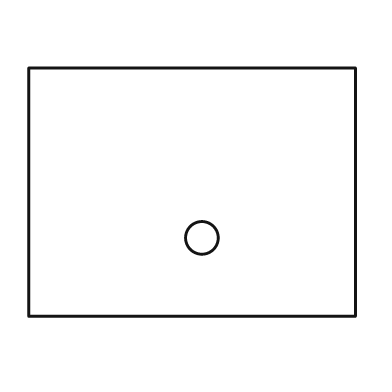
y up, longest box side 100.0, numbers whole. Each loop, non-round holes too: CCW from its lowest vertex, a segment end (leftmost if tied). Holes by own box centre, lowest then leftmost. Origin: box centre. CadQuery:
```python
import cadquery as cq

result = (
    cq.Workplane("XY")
    .moveTo(-50.0, -38.0)
    .lineTo(50.0, -38.0)
    .lineTo(50.0, 38.0)
    .lineTo(-50.0, 38.0)
    .close()
    .moveTo(3.0, -14.0)
    .circle(5.0)
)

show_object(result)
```